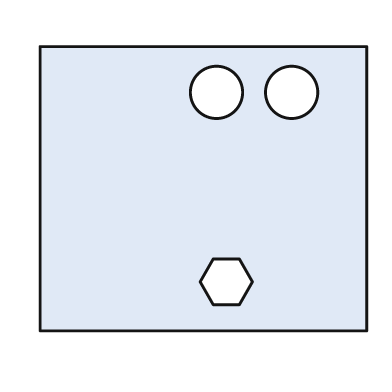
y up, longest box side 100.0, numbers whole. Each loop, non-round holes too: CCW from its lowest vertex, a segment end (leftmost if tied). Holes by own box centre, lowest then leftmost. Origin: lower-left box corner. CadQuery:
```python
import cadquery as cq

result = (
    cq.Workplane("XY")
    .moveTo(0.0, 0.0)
    .lineTo(100.0, 0.0)
    .lineTo(100.0, 87.0)
    .lineTo(0.0, 87.0)
    .close()
    .moveTo(53.0, 8.0)
    .lineTo(61.0, 8.0)
    .lineTo(65.0, 15.0)
    .lineTo(61.0, 22.0)
    .lineTo(53.0, 22.0)
    .lineTo(49.0, 15.0)
    .close()
    .moveTo(54.0, 73.0)
    .circle(8.0)
    .moveTo(77.0, 73.0)
    .circle(8.0)
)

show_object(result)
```